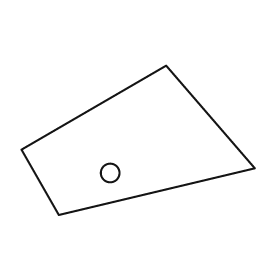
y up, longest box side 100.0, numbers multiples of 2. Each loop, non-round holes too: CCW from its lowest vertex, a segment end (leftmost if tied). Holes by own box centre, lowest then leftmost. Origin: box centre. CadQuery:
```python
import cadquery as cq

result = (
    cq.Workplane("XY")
    .moveTo(-34.0, -32.0)
    .lineTo(50.0, -12.0)
    .lineTo(12.0, 32.0)
    .lineTo(-50.0, -4.0)
    .close()
    .moveTo(-12.0, -14.0)
    .circle(4.0)
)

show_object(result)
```